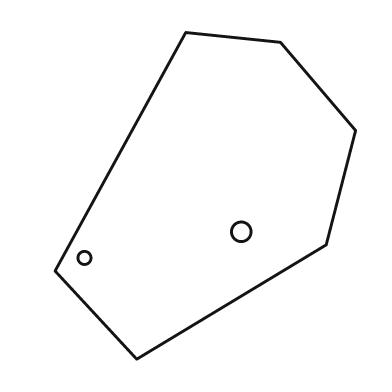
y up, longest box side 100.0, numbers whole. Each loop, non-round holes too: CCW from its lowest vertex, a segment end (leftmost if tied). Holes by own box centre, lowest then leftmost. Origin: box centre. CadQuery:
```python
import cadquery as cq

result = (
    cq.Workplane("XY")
    .moveTo(-21.0, -50.0)
    .lineTo(37.0, -15.0)
    .lineTo(46.0, 20.0)
    .lineTo(23.0, 47.0)
    .lineTo(-6.0, 50.0)
    .lineTo(-46.0, -23.0)
    .close()
    .moveTo(-37.0, -19.0)
    .circle(2.0)
    .moveTo(11.0, -11.0)
    .circle(3.0)
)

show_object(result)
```